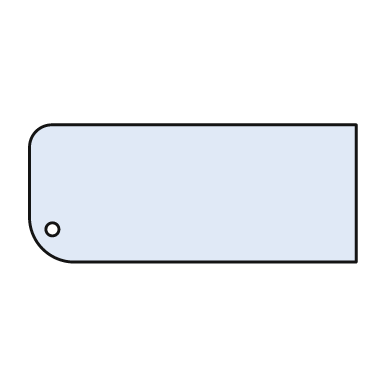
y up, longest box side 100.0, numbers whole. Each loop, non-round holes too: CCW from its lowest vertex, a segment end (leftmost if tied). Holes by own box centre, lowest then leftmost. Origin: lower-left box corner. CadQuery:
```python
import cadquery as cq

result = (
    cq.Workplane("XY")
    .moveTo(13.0, 0.0)
    .lineTo(100.0, 0.0)
    .lineTo(100.0, 42.0)
    .lineTo(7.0, 42.0)
    .threePointArc((2.0, 40.0), (0.0, 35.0))
    .lineTo(0.0, 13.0)
    .threePointArc((4.0, 4.0), (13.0, 0.0))
    .close()
    .moveTo(7.0, 10.0)
    .circle(2.0)
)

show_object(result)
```